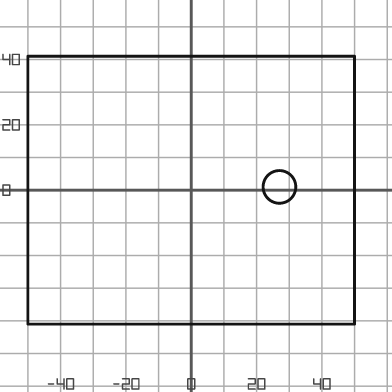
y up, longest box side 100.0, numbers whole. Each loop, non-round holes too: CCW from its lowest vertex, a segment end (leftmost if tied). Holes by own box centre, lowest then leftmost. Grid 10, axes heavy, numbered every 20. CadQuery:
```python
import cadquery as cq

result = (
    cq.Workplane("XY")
    .moveTo(-50.0, -41.0)
    .lineTo(50.0, -41.0)
    .lineTo(50.0, 41.0)
    .lineTo(-50.0, 41.0)
    .close()
    .moveTo(27.0, 1.0)
    .circle(5.0)
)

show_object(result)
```